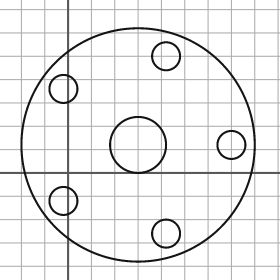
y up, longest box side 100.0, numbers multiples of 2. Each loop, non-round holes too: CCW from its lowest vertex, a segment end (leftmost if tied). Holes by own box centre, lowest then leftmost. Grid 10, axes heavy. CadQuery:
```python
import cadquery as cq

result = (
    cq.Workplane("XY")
    .moveTo(30.0, 12.0)
    .circle(50.0)
    .moveTo(42.0, -26.0)
    .circle(6.0)
    .moveTo(-2.0, -12.0)
    .circle(6.0)
    .moveTo(30.0, 12.0)
    .circle(12.0)
    .moveTo(70.0, 12.0)
    .circle(6.0)
    .moveTo(-2.0, 36.0)
    .circle(6.0)
    .moveTo(42.0, 50.0)
    .circle(6.0)
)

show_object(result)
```